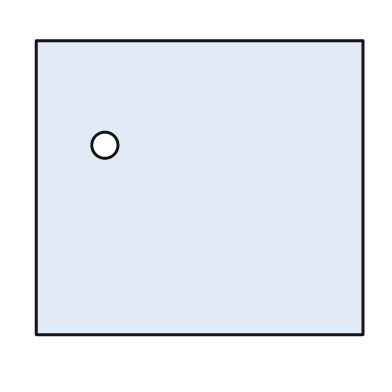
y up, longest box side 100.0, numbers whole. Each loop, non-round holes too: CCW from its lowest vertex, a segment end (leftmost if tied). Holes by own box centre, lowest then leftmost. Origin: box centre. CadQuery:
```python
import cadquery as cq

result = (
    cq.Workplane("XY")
    .moveTo(-50.0, -45.0)
    .lineTo(50.0, -45.0)
    .lineTo(50.0, 45.0)
    .lineTo(-50.0, 45.0)
    .close()
    .moveTo(-29.0, 13.0)
    .circle(4.0)
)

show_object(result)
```